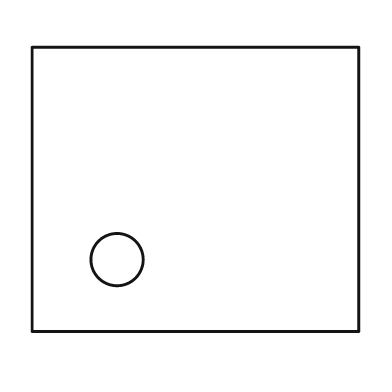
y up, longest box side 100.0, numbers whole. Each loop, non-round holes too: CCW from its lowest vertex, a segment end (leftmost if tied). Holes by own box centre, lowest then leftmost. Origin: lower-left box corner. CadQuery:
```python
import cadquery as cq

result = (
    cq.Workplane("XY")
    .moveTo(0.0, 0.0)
    .lineTo(100.0, 0.0)
    .lineTo(100.0, 87.0)
    .lineTo(0.0, 87.0)
    .close()
    .moveTo(26.0, 22.0)
    .circle(8.0)
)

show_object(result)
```